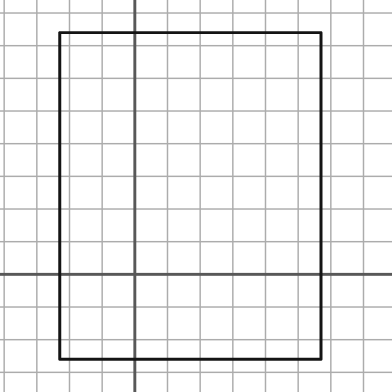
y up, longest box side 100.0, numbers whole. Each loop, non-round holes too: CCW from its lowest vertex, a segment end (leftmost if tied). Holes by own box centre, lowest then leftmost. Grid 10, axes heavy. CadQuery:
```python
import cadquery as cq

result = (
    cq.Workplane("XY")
    .moveTo(-23.0, -26.0)
    .lineTo(57.0, -26.0)
    .lineTo(57.0, 74.0)
    .lineTo(-23.0, 74.0)
    .close()
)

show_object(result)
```